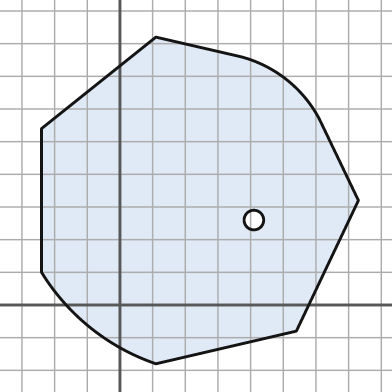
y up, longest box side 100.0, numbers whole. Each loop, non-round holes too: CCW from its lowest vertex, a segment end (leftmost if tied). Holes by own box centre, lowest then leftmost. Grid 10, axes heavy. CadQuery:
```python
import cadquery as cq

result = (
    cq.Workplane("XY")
    .moveTo(11.0, -18.0)
    .lineTo(54.0, -8.0)
    .lineTo(73.0, 32.0)
    .lineTo(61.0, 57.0)
    .threePointArc((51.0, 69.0), (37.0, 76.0))
    .lineTo(11.0, 82.0)
    .lineTo(-24.0, 54.0)
    .lineTo(-24.0, 10.0)
    .threePointArc((-9.0, -7.0), (11.0, -18.0))
    .close()
    .moveTo(41.0, 26.0)
    .circle(3.0)
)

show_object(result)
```